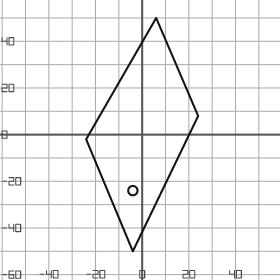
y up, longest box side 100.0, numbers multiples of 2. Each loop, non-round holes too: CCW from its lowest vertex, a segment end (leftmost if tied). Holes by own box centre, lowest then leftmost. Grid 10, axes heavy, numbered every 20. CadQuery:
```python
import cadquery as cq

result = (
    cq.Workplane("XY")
    .moveTo(-4.0, -50.0)
    .lineTo(24.0, 8.0)
    .lineTo(6.0, 50.0)
    .lineTo(-24.0, -2.0)
    .close()
    .moveTo(-4.0, -24.0)
    .circle(2.0)
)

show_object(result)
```